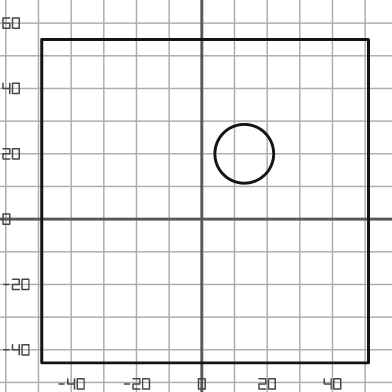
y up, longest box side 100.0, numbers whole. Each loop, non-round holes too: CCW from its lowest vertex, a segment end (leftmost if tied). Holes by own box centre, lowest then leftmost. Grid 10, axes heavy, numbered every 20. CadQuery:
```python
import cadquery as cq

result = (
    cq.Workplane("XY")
    .moveTo(-49.0, -44.0)
    .lineTo(51.0, -44.0)
    .lineTo(51.0, 55.0)
    .lineTo(-49.0, 55.0)
    .close()
    .moveTo(13.0, 20.0)
    .circle(9.0)
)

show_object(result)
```